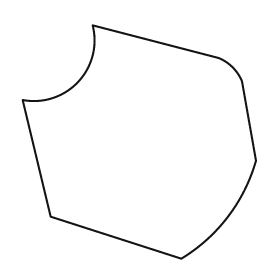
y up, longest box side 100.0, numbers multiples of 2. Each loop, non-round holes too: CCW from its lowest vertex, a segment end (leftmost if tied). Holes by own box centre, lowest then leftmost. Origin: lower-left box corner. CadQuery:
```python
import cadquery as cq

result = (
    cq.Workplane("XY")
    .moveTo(68.0, 0.0)
    .threePointArc((88.0, 18.0), (100.0, 42.0))
    .lineTo(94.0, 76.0)
    .threePointArc((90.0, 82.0), (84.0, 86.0))
    .lineTo(30.0, 100.0)
    .threePointArc((24.0, 76.0), (0.0, 68.0))
    .lineTo(12.0, 18.0)
    .close()
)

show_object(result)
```